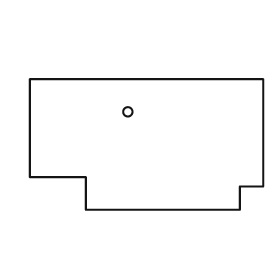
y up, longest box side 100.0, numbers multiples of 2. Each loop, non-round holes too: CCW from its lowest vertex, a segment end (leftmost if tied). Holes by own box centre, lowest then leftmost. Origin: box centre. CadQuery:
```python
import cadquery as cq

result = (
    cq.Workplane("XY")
    .moveTo(-26.0, -28.0)
    .lineTo(40.0, -28.0)
    .lineTo(40.0, -18.0)
    .lineTo(50.0, -18.0)
    .lineTo(50.0, 28.0)
    .lineTo(-50.0, 28.0)
    .lineTo(-50.0, -14.0)
    .lineTo(-26.0, -14.0)
    .close()
    .moveTo(-8.0, 14.0)
    .circle(2.0)
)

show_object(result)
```